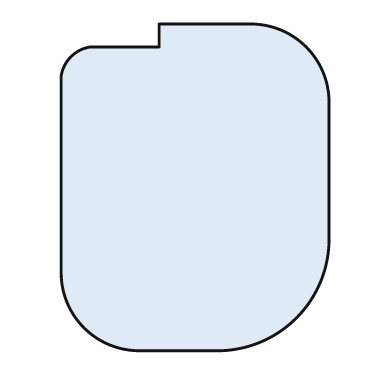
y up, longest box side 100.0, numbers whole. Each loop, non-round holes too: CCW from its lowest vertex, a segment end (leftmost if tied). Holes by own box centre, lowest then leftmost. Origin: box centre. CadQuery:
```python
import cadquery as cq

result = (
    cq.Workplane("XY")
    .moveTo(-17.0, -50.0)
    .lineTo(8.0, -50.0)
    .threePointArc((31.0, -40.0), (41.0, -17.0))
    .lineTo(41.0, 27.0)
    .threePointArc((34.0, 43.0), (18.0, 50.0))
    .lineTo(-11.0, 50.0)
    .lineTo(-11.0, 43.0)
    .lineTo(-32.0, 43.0)
    .threePointArc((-38.0, 40.0), (-41.0, 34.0))
    .lineTo(-41.0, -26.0)
    .threePointArc((-34.0, -43.0), (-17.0, -50.0))
    .close()
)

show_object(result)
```